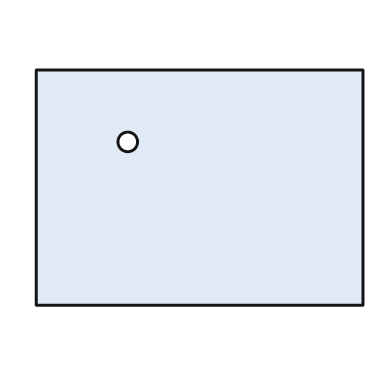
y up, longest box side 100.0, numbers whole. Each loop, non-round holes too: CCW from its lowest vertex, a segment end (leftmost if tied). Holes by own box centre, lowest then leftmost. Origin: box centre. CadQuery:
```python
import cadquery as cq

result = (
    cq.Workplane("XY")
    .moveTo(-50.0, -36.0)
    .lineTo(50.0, -36.0)
    .lineTo(50.0, 36.0)
    .lineTo(-50.0, 36.0)
    .close()
    .moveTo(-22.0, 14.0)
    .circle(3.0)
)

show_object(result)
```